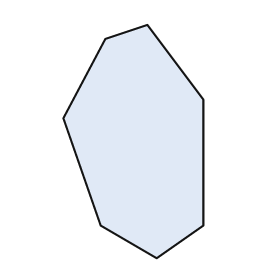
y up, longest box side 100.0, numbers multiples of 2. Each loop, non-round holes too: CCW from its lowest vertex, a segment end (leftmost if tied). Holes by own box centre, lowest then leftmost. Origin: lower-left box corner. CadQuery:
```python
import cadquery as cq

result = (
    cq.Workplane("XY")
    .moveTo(40.0, 0.0)
    .lineTo(60.0, 14.0)
    .lineTo(60.0, 68.0)
    .lineTo(36.0, 100.0)
    .lineTo(18.0, 94.0)
    .lineTo(0.0, 60.0)
    .lineTo(16.0, 14.0)
    .close()
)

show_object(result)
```